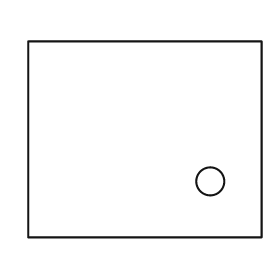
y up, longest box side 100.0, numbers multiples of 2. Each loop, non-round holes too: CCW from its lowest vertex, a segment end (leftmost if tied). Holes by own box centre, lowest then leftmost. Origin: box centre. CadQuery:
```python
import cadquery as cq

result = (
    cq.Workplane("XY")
    .moveTo(-50.0, -42.0)
    .lineTo(50.0, -42.0)
    .lineTo(50.0, 42.0)
    .lineTo(-50.0, 42.0)
    .close()
    .moveTo(28.0, -18.0)
    .circle(6.0)
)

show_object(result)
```